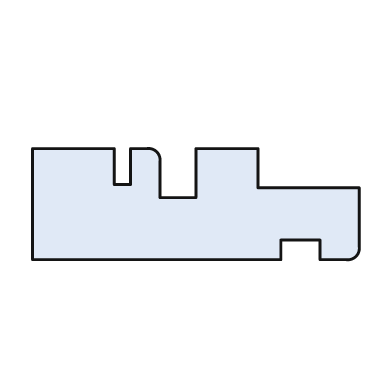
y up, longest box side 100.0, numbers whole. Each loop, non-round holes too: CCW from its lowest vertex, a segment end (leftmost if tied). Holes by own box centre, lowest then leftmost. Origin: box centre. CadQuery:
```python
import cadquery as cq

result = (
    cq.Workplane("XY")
    .moveTo(-50.0, -17.0)
    .lineTo(26.0, -17.0)
    .lineTo(26.0, -11.0)
    .lineTo(38.0, -11.0)
    .lineTo(38.0, -17.0)
    .lineTo(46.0, -17.0)
    .threePointArc((49.0, -16.0), (50.0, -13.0))
    .lineTo(50.0, 5.0)
    .lineTo(19.0, 5.0)
    .lineTo(19.0, 17.0)
    .lineTo(0.0, 17.0)
    .lineTo(0.0, 2.0)
    .lineTo(-11.0, 2.0)
    .lineTo(-11.0, 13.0)
    .threePointArc((-12.0, 16.0), (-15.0, 17.0))
    .lineTo(-20.0, 17.0)
    .lineTo(-20.0, 6.0)
    .lineTo(-25.0, 6.0)
    .lineTo(-25.0, 17.0)
    .lineTo(-50.0, 17.0)
    .close()
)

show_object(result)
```